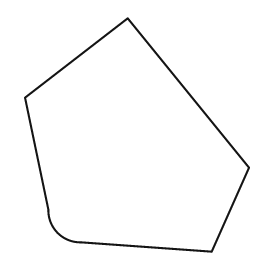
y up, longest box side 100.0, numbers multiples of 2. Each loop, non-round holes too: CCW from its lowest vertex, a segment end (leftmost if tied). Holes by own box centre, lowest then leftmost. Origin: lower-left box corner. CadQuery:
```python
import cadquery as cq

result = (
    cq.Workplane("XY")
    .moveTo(80.0, 0.0)
    .lineTo(96.0, 36.0)
    .lineTo(44.0, 100.0)
    .lineTo(0.0, 66.0)
    .lineTo(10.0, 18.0)
    .threePointArc((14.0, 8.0), (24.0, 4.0))
    .close()
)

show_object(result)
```